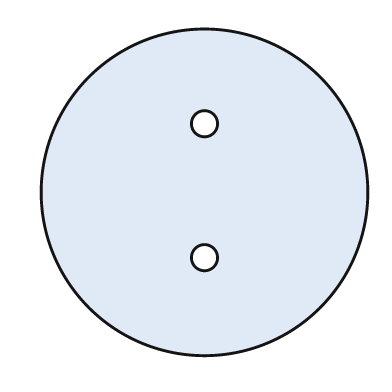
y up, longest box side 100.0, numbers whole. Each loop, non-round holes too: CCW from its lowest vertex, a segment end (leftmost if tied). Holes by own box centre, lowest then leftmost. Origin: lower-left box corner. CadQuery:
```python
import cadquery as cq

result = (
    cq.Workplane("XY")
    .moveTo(50.0, 50.0)
    .circle(50.0)
    .moveTo(50.0, 30.0)
    .circle(4.0)
    .moveTo(50.0, 71.0)
    .circle(4.0)
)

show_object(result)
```